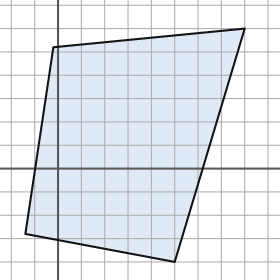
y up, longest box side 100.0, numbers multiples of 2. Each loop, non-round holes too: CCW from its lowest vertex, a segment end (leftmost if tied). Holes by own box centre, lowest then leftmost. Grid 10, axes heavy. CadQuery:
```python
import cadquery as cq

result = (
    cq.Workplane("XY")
    .moveTo(50.0, -40.0)
    .lineTo(80.0, 60.0)
    .lineTo(-2.0, 52.0)
    .lineTo(-14.0, -28.0)
    .close()
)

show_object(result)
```